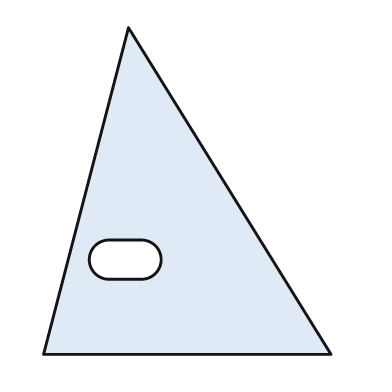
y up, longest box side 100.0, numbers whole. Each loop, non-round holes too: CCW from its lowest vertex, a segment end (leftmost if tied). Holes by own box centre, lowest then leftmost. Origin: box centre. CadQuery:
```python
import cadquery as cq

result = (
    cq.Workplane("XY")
    .moveTo(-44.0, -50.0)
    .lineTo(44.0, -50.0)
    .lineTo(-18.0, 50.0)
    .close()
    .moveTo(-24.0, -27.0)
    .lineTo(-14.0, -27.0)
    .threePointArc((-8.0, -21.0), (-14.0, -15.0))
    .lineTo(-24.0, -15.0)
    .threePointArc((-30.0, -21.0), (-24.0, -27.0))
    .close()
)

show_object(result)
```